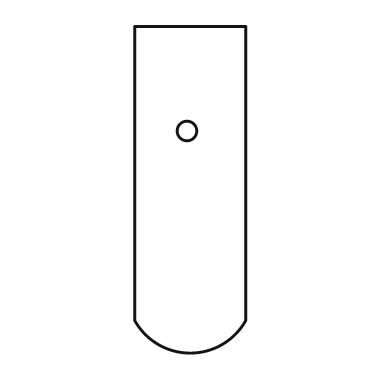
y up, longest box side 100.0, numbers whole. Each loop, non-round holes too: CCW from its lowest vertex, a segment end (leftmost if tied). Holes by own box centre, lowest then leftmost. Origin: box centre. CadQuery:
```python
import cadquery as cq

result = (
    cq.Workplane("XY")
    .moveTo(-17.0, -40.0)
    .threePointArc((0.0, -50.0), (17.0, -40.0))
    .lineTo(17.0, 50.0)
    .lineTo(-17.0, 50.0)
    .close()
    .moveTo(-1.0, 18.0)
    .circle(3.0)
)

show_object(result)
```